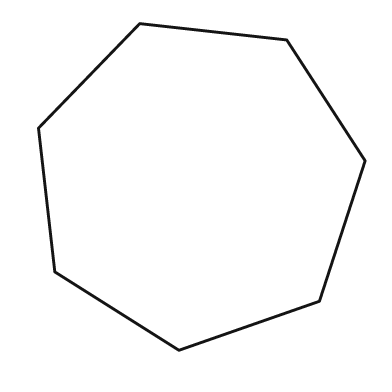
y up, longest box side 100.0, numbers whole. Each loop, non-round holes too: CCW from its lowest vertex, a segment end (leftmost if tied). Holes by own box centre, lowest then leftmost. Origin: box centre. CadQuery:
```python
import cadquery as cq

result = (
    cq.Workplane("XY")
    .moveTo(-7.0, -50.0)
    .lineTo(36.0, -35.0)
    .lineTo(50.0, 8.0)
    .lineTo(26.0, 45.0)
    .lineTo(-19.0, 50.0)
    .lineTo(-50.0, 18.0)
    .lineTo(-45.0, -26.0)
    .close()
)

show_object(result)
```